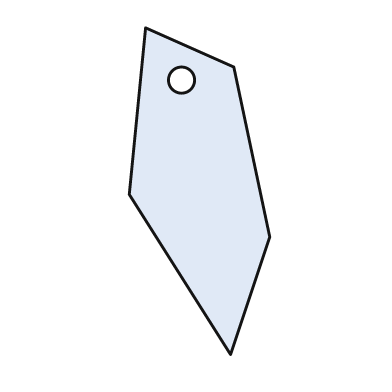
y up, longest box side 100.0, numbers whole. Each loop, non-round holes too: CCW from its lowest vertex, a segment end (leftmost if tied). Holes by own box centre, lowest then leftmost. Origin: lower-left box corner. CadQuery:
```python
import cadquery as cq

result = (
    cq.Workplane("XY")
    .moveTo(31.0, 0.0)
    .lineTo(43.0, 36.0)
    .lineTo(32.0, 88.0)
    .lineTo(5.0, 100.0)
    .lineTo(0.0, 49.0)
    .close()
    .moveTo(16.0, 84.0)
    .circle(4.0)
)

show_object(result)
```